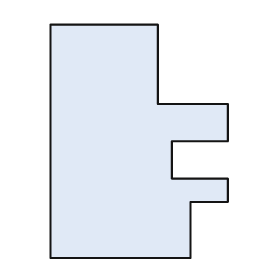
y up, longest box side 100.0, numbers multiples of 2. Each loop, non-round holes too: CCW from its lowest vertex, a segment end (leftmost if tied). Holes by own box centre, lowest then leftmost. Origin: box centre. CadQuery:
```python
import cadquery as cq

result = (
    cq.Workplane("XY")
    .moveTo(-38.0, -50.0)
    .lineTo(22.0, -50.0)
    .lineTo(22.0, -26.0)
    .lineTo(38.0, -26.0)
    .lineTo(38.0, -16.0)
    .lineTo(14.0, -16.0)
    .lineTo(14.0, 0.0)
    .lineTo(38.0, 0.0)
    .lineTo(38.0, 16.0)
    .lineTo(8.0, 16.0)
    .lineTo(8.0, 50.0)
    .lineTo(-38.0, 50.0)
    .close()
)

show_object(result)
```